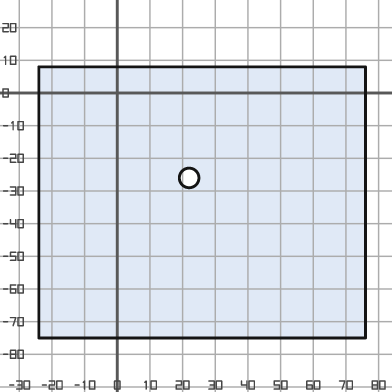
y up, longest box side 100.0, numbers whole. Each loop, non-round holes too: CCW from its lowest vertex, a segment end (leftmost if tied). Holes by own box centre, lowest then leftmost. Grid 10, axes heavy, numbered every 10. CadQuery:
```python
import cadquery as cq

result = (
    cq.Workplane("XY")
    .moveTo(-24.0, -75.0)
    .lineTo(76.0, -75.0)
    .lineTo(76.0, 8.0)
    .lineTo(-24.0, 8.0)
    .close()
    .moveTo(22.0, -26.0)
    .circle(3.0)
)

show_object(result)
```